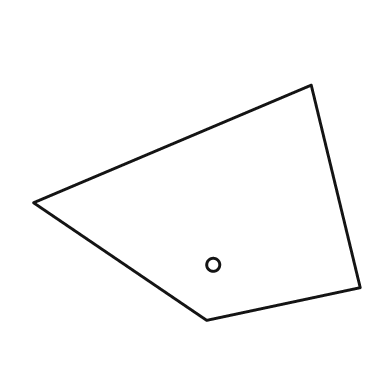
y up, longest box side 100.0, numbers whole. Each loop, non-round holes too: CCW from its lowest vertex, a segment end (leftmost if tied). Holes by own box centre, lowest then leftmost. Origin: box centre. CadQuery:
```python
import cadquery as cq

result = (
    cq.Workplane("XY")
    .moveTo(3.0, -36.0)
    .lineTo(50.0, -26.0)
    .lineTo(35.0, 36.0)
    .lineTo(-50.0, 0.0)
    .close()
    .moveTo(5.0, -19.0)
    .circle(2.0)
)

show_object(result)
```